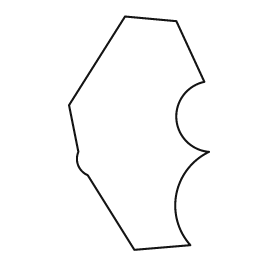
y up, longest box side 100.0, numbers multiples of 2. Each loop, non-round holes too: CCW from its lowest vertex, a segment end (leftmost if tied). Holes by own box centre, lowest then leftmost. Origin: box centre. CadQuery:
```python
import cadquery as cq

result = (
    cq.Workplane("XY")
    .moveTo(-2.0, -50.0)
    .lineTo(22.0, -48.0)
    .threePointArc((16.0, -26.0), (30.0, -8.0))
    .threePointArc((16.0, 6.0), (28.0, 22.0))
    .lineTo(16.0, 48.0)
    .lineTo(-6.0, 50.0)
    .lineTo(-30.0, 12.0)
    .lineTo(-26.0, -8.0)
    .threePointArc((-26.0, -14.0), (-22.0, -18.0))
    .close()
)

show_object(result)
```